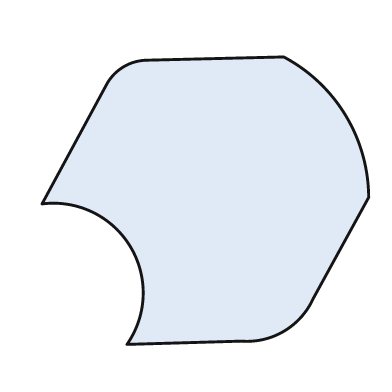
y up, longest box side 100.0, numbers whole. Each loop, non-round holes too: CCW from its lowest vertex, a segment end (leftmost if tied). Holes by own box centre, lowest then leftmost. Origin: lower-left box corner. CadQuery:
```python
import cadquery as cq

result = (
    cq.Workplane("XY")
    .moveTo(26.0, 0.0)
    .lineTo(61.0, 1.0)
    .threePointArc((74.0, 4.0), (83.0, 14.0))
    .lineTo(100.0, 45.0)
    .threePointArc((93.0, 70.0), (74.0, 88.0))
    .lineTo(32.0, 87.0)
    .threePointArc((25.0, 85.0), (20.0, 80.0))
    .lineTo(0.0, 43.0)
    .threePointArc((27.0, 30.0), (26.0, 0.0))
    .close()
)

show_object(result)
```